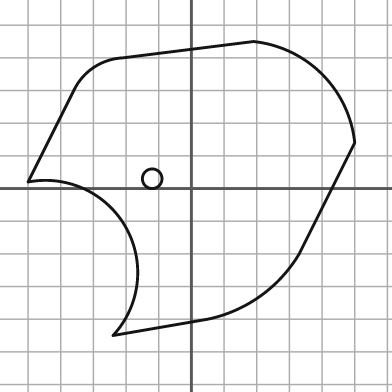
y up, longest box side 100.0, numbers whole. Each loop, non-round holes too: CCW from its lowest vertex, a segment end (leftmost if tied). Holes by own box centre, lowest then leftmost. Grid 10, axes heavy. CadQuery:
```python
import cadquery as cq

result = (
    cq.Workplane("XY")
    .moveTo(-24.0, -45.0)
    .lineTo(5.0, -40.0)
    .threePointArc((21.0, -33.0), (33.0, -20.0))
    .lineTo(50.0, 14.0)
    .threePointArc((40.0, 35.0), (19.0, 45.0))
    .lineTo(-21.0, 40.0)
    .threePointArc((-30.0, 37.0), (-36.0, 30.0))
    .lineTo(-50.0, 2.0)
    .threePointArc((-20.0, -12.0), (-24.0, -45.0))
    .close()
    .moveTo(-12.0, 3.0)
    .circle(3.0)
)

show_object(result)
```